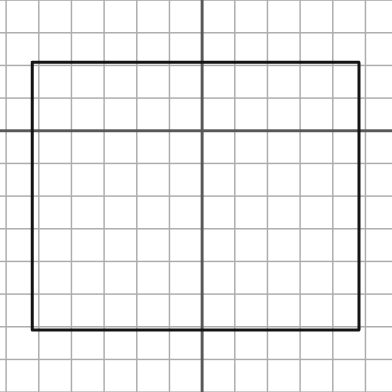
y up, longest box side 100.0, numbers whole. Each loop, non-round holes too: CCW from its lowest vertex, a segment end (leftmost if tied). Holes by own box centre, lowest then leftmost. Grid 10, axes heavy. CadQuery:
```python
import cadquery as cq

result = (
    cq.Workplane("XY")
    .moveTo(-52.0, -61.0)
    .lineTo(48.0, -61.0)
    .lineTo(48.0, 21.0)
    .lineTo(-52.0, 21.0)
    .close()
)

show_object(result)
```